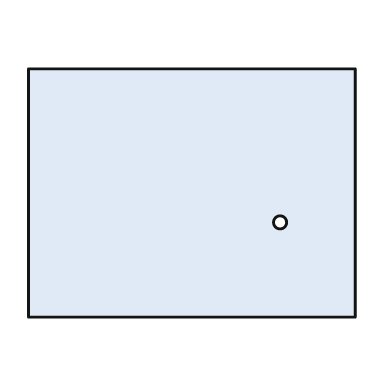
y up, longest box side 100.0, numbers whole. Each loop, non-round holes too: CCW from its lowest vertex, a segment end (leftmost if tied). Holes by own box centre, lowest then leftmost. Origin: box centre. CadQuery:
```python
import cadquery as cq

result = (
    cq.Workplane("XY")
    .moveTo(-50.0, -38.0)
    .lineTo(50.0, -38.0)
    .lineTo(50.0, 38.0)
    .lineTo(-50.0, 38.0)
    .close()
    .moveTo(27.0, -9.0)
    .circle(2.0)
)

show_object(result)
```